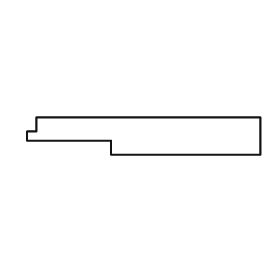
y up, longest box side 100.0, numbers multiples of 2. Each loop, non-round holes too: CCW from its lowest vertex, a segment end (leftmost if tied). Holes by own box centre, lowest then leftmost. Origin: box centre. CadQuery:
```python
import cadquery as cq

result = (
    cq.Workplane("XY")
    .moveTo(-14.0, -8.0)
    .lineTo(50.0, -8.0)
    .lineTo(50.0, 8.0)
    .lineTo(-46.0, 8.0)
    .lineTo(-46.0, 2.0)
    .lineTo(-50.0, 2.0)
    .lineTo(-50.0, -2.0)
    .lineTo(-14.0, -2.0)
    .close()
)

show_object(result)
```